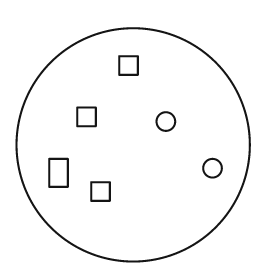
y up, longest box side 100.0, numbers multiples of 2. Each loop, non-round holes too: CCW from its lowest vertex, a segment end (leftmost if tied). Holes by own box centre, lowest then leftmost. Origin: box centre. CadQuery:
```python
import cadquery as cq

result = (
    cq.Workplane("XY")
    .moveTo(0.0, 0.0)
    .circle(50.0)
    .moveTo(-18.0, -24.0)
    .lineTo(-10.0, -24.0)
    .lineTo(-10.0, -16.0)
    .lineTo(-18.0, -16.0)
    .close()
    .moveTo(-36.0, -18.0)
    .lineTo(-28.0, -18.0)
    .lineTo(-28.0, -6.0)
    .lineTo(-36.0, -6.0)
    .close()
    .moveTo(34.0, -10.0)
    .circle(4.0)
    .moveTo(14.0, 10.0)
    .circle(4.0)
    .moveTo(-24.0, 8.0)
    .lineTo(-16.0, 8.0)
    .lineTo(-16.0, 16.0)
    .lineTo(-24.0, 16.0)
    .close()
    .moveTo(-6.0, 30.0)
    .lineTo(2.0, 30.0)
    .lineTo(2.0, 38.0)
    .lineTo(-6.0, 38.0)
    .close()
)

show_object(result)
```